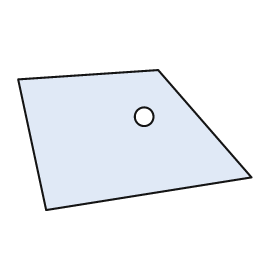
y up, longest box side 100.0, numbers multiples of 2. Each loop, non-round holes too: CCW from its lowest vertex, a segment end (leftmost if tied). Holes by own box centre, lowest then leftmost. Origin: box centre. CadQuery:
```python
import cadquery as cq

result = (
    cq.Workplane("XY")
    .moveTo(-38.0, -30.0)
    .lineTo(50.0, -16.0)
    .lineTo(10.0, 30.0)
    .lineTo(-50.0, 26.0)
    .close()
    .moveTo(4.0, 10.0)
    .circle(4.0)
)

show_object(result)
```